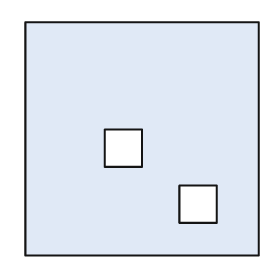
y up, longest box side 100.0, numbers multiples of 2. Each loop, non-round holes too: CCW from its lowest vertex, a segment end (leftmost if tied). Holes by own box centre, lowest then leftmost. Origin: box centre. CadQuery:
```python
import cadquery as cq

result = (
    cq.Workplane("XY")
    .moveTo(-50.0, -50.0)
    .lineTo(50.0, -50.0)
    .lineTo(50.0, 50.0)
    .lineTo(-50.0, 50.0)
    .close()
    .moveTo(16.0, -36.0)
    .lineTo(32.0, -36.0)
    .lineTo(32.0, -20.0)
    .lineTo(16.0, -20.0)
    .close()
    .moveTo(-16.0, -12.0)
    .lineTo(0.0, -12.0)
    .lineTo(0.0, 4.0)
    .lineTo(-16.0, 4.0)
    .close()
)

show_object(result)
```